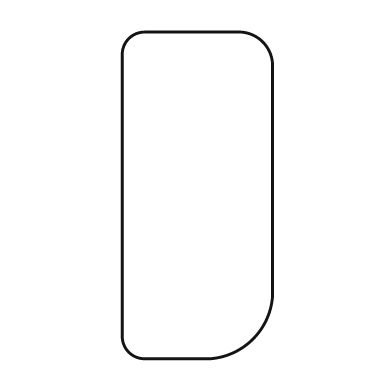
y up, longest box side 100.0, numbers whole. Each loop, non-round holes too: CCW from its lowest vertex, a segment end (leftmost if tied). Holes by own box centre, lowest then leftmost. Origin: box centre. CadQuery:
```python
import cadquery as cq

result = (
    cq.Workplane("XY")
    .moveTo(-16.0, -50.0)
    .lineTo(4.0, -50.0)
    .threePointArc((17.0, -44.0), (23.0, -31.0))
    .lineTo(23.0, 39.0)
    .threePointArc((20.0, 47.0), (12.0, 50.0))
    .lineTo(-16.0, 50.0)
    .threePointArc((-21.0, 48.0), (-23.0, 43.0))
    .lineTo(-23.0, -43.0)
    .threePointArc((-21.0, -48.0), (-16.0, -50.0))
    .close()
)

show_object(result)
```